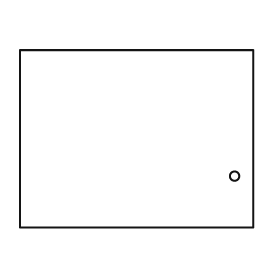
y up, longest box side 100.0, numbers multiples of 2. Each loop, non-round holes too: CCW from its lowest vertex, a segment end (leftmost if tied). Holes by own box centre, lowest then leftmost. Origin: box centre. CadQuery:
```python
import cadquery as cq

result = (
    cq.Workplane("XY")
    .moveTo(-50.0, -38.0)
    .lineTo(50.0, -38.0)
    .lineTo(50.0, 38.0)
    .lineTo(-50.0, 38.0)
    .close()
    .moveTo(42.0, -16.0)
    .circle(2.0)
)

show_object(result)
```